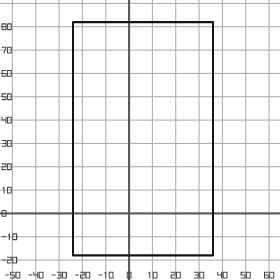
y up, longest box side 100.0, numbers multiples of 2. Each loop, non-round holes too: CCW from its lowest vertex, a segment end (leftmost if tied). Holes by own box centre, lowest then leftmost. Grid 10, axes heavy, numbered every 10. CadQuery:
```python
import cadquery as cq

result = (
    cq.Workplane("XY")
    .moveTo(-24.0, -18.0)
    .lineTo(36.0, -18.0)
    .lineTo(36.0, 82.0)
    .lineTo(-24.0, 82.0)
    .close()
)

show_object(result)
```